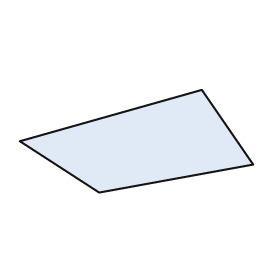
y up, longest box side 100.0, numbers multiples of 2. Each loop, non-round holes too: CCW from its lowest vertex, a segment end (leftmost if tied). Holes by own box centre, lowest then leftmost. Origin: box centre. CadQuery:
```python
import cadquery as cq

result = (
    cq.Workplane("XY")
    .moveTo(-16.0, -22.0)
    .lineTo(50.0, -10.0)
    .lineTo(28.0, 22.0)
    .lineTo(-50.0, 0.0)
    .close()
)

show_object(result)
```